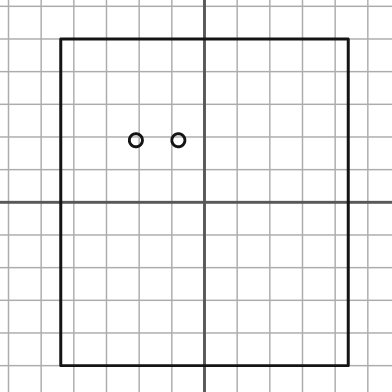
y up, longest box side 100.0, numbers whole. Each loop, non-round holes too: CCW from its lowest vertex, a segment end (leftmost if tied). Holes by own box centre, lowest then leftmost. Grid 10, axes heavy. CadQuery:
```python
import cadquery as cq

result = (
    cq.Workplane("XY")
    .moveTo(-44.0, -50.0)
    .lineTo(44.0, -50.0)
    .lineTo(44.0, 50.0)
    .lineTo(-44.0, 50.0)
    .close()
    .moveTo(-21.0, 19.0)
    .circle(2.0)
    .moveTo(-8.0, 19.0)
    .circle(2.0)
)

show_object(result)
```